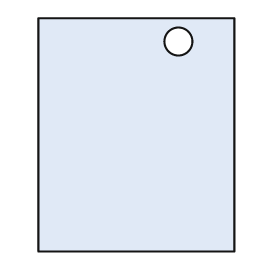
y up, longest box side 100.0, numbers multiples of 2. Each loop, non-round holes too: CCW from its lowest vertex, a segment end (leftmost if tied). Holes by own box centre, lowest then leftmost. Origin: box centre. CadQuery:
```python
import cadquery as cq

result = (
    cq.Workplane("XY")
    .moveTo(-42.0, -50.0)
    .lineTo(42.0, -50.0)
    .lineTo(42.0, 50.0)
    .lineTo(-42.0, 50.0)
    .close()
    .moveTo(18.0, 40.0)
    .circle(6.0)
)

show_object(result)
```